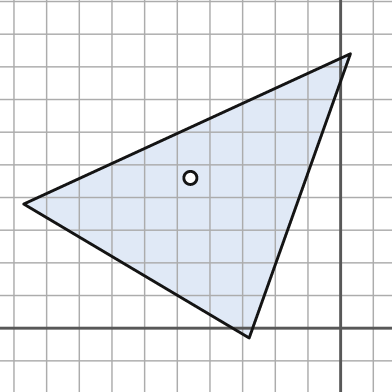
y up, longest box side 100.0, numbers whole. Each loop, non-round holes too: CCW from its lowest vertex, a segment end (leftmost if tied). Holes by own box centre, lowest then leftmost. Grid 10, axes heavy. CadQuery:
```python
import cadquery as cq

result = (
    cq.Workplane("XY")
    .moveTo(-28.0, -3.0)
    .lineTo(3.0, 84.0)
    .lineTo(-97.0, 38.0)
    .close()
    .moveTo(-46.0, 46.0)
    .circle(2.0)
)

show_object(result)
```